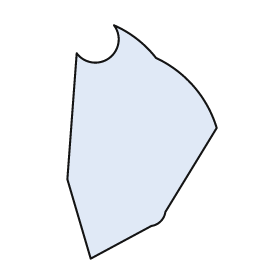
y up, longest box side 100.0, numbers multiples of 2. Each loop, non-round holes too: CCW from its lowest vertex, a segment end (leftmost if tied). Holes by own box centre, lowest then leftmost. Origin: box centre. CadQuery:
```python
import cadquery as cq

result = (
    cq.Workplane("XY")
    .moveTo(-22.0, -50.0)
    .lineTo(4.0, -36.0)
    .threePointArc((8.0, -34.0), (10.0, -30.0))
    .lineTo(32.0, 6.0)
    .threePointArc((22.0, 24.0), (6.0, 36.0))
    .threePointArc((-2.0, 44.0), (-12.0, 50.0))
    .threePointArc((-14.0, 36.0), (-28.0, 38.0))
    .lineTo(-32.0, -16.0)
    .close()
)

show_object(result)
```